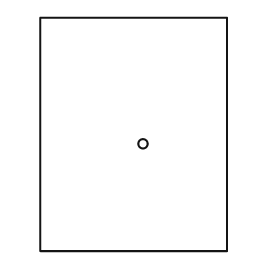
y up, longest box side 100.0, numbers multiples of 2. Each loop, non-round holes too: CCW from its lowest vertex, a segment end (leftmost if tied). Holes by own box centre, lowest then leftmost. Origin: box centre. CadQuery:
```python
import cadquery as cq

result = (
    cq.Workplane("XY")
    .moveTo(-40.0, -50.0)
    .lineTo(40.0, -50.0)
    .lineTo(40.0, 50.0)
    .lineTo(-40.0, 50.0)
    .close()
    .moveTo(4.0, -4.0)
    .circle(2.0)
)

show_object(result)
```